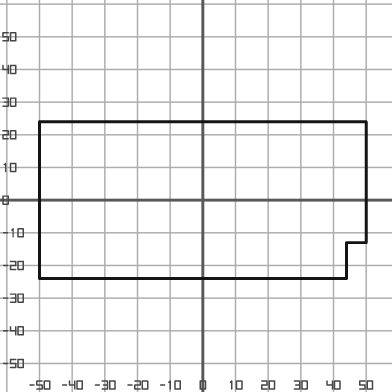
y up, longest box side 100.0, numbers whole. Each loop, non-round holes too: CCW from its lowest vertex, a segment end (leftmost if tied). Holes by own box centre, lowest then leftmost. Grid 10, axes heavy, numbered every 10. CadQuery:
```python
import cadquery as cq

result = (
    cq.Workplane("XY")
    .moveTo(-50.0, -24.0)
    .lineTo(44.0, -24.0)
    .lineTo(44.0, -13.0)
    .lineTo(50.0, -13.0)
    .lineTo(50.0, 24.0)
    .lineTo(-50.0, 24.0)
    .close()
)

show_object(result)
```